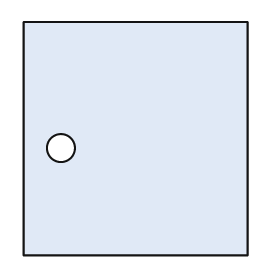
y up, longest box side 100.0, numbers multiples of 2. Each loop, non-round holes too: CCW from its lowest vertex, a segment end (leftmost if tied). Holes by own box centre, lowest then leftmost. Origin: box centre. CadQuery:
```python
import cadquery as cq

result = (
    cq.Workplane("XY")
    .moveTo(-48.0, -50.0)
    .lineTo(48.0, -50.0)
    .lineTo(48.0, 50.0)
    .lineTo(-48.0, 50.0)
    .close()
    .moveTo(-32.0, -4.0)
    .circle(6.0)
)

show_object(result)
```